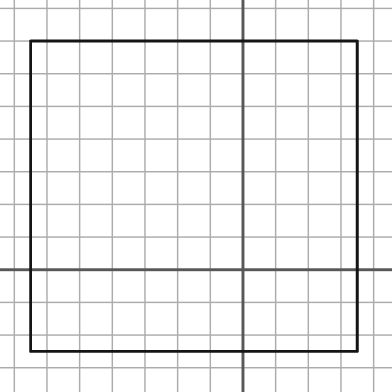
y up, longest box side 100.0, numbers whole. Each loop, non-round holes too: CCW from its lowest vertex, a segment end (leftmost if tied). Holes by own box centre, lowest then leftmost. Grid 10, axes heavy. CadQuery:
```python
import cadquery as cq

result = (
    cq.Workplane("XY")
    .moveTo(-65.0, -25.0)
    .lineTo(35.0, -25.0)
    .lineTo(35.0, 70.0)
    .lineTo(-65.0, 70.0)
    .close()
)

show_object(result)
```